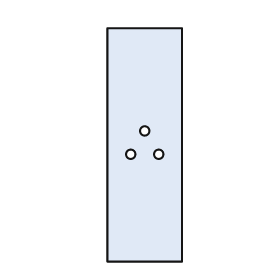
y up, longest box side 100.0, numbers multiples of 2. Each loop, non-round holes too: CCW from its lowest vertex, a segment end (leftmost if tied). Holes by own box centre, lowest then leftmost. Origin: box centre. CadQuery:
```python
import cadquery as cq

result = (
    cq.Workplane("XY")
    .moveTo(-16.0, -50.0)
    .lineTo(16.0, -50.0)
    .lineTo(16.0, 50.0)
    .lineTo(-16.0, 50.0)
    .close()
    .moveTo(-6.0, -4.0)
    .circle(2.0)
    .moveTo(6.0, -4.0)
    .circle(2.0)
    .moveTo(0.0, 6.0)
    .circle(2.0)
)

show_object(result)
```